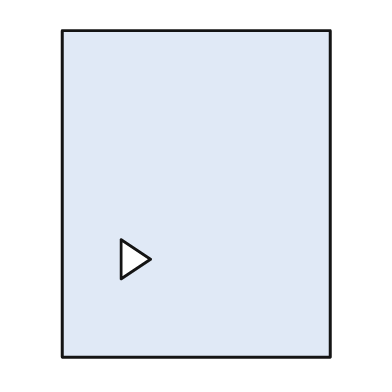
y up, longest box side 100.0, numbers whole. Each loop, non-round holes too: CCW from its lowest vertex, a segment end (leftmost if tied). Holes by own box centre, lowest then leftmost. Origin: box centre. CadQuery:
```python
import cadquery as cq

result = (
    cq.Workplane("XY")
    .moveTo(-41.0, -50.0)
    .lineTo(41.0, -50.0)
    .lineTo(41.0, 50.0)
    .lineTo(-41.0, 50.0)
    .close()
    .moveTo(-23.0, -26.0)
    .lineTo(-14.0, -20.0)
    .lineTo(-23.0, -14.0)
    .close()
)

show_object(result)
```